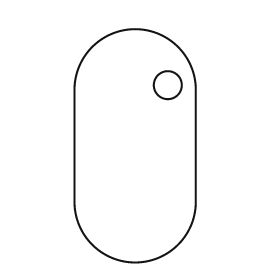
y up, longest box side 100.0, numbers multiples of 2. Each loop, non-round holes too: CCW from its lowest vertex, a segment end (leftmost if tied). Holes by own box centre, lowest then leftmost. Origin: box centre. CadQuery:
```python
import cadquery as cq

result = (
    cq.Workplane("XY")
    .moveTo(-26.0, -24.0)
    .threePointArc((0.0, -50.0), (26.0, -24.0))
    .lineTo(26.0, 24.0)
    .threePointArc((0.0, 50.0), (-26.0, 24.0))
    .close()
    .moveTo(14.0, 26.0)
    .circle(6.0)
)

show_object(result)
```